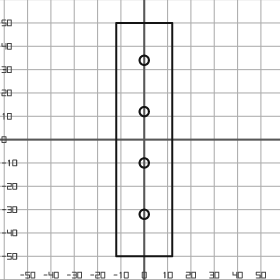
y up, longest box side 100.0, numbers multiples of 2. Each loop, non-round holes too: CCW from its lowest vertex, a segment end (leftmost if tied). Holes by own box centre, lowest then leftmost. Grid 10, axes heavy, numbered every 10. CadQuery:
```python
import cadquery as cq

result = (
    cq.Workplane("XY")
    .moveTo(-12.0, -50.0)
    .lineTo(12.0, -50.0)
    .lineTo(12.0, 50.0)
    .lineTo(-12.0, 50.0)
    .close()
    .moveTo(0.0, -32.0)
    .circle(2.0)
    .moveTo(0.0, -10.0)
    .circle(2.0)
    .moveTo(0.0, 12.0)
    .circle(2.0)
    .moveTo(0.0, 34.0)
    .circle(2.0)
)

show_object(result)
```